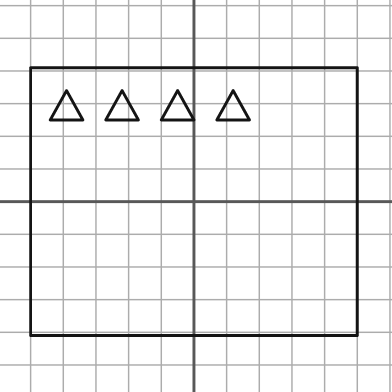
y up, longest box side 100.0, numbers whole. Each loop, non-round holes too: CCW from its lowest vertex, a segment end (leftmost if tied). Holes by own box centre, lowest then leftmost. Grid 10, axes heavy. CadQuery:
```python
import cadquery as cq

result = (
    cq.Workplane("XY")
    .moveTo(-50.0, -41.0)
    .lineTo(50.0, -41.0)
    .lineTo(50.0, 41.0)
    .lineTo(-50.0, 41.0)
    .close()
    .moveTo(-44.0, 25.0)
    .lineTo(-34.0, 25.0)
    .lineTo(-39.0, 34.0)
    .close()
    .moveTo(-27.0, 25.0)
    .lineTo(-17.0, 25.0)
    .lineTo(-22.0, 34.0)
    .close()
    .moveTo(-10.0, 25.0)
    .lineTo(0.0, 25.0)
    .lineTo(-5.0, 34.0)
    .close()
    .moveTo(7.0, 25.0)
    .lineTo(17.0, 25.0)
    .lineTo(12.0, 34.0)
    .close()
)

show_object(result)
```